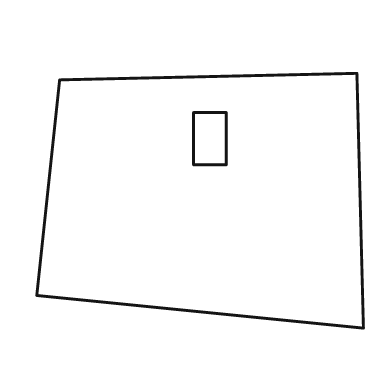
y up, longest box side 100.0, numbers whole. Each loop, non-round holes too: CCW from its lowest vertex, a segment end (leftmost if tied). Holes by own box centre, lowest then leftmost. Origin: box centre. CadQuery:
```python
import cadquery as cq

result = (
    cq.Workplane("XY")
    .moveTo(50.0, -39.0)
    .lineTo(48.0, 39.0)
    .lineTo(-43.0, 37.0)
    .lineTo(-50.0, -29.0)
    .close()
    .moveTo(-2.0, 11.0)
    .lineTo(8.0, 11.0)
    .lineTo(8.0, 27.0)
    .lineTo(-2.0, 27.0)
    .close()
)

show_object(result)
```